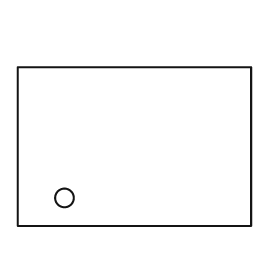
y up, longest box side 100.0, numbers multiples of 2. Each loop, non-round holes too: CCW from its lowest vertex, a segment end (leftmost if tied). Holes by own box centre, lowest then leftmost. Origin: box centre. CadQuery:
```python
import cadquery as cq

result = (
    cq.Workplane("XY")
    .moveTo(-50.0, -34.0)
    .lineTo(50.0, -34.0)
    .lineTo(50.0, 34.0)
    .lineTo(-50.0, 34.0)
    .close()
    .moveTo(-30.0, -22.0)
    .circle(4.0)
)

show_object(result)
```